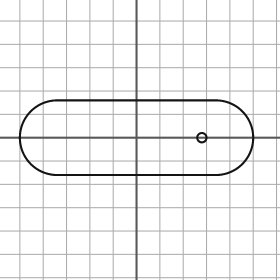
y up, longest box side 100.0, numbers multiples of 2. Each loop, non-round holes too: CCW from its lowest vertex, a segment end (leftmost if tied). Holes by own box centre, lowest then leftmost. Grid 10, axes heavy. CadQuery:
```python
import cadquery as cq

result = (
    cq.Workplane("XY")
    .moveTo(-34.0, -16.0)
    .lineTo(34.0, -16.0)
    .threePointArc((50.0, 0.0), (34.0, 16.0))
    .lineTo(-34.0, 16.0)
    .threePointArc((-50.0, 0.0), (-34.0, -16.0))
    .close()
    .moveTo(28.0, 0.0)
    .circle(2.0)
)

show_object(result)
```